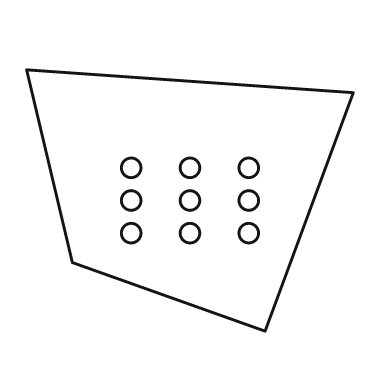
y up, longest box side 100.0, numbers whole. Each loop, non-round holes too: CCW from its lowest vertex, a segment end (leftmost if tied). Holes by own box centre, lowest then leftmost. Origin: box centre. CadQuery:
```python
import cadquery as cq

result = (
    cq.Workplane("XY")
    .moveTo(23.0, -40.0)
    .lineTo(50.0, 33.0)
    .lineTo(-50.0, 40.0)
    .lineTo(-36.0, -19.0)
    .close()
    .moveTo(-18.0, -10.0)
    .circle(3.0)
    .moveTo(0.0, -10.0)
    .circle(3.0)
    .moveTo(18.0, -10.0)
    .circle(3.0)
    .moveTo(-18.0, 0.0)
    .circle(3.0)
    .moveTo(0.0, 0.0)
    .circle(3.0)
    .moveTo(18.0, 0.0)
    .circle(3.0)
    .moveTo(-18.0, 10.0)
    .circle(3.0)
    .moveTo(0.0, 10.0)
    .circle(3.0)
    .moveTo(18.0, 10.0)
    .circle(3.0)
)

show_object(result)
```